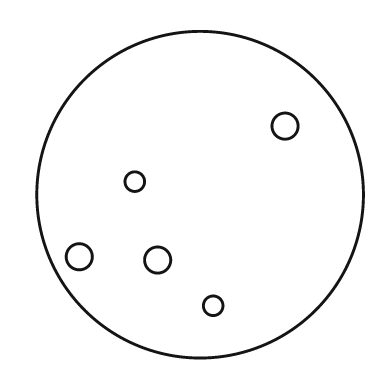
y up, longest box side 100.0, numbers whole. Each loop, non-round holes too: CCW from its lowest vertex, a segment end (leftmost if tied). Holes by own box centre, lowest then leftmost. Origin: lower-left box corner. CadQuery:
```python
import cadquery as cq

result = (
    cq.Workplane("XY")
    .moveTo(50.0, 50.0)
    .circle(50.0)
    .moveTo(54.0, 16.0)
    .circle(3.0)
    .moveTo(37.0, 30.0)
    .circle(4.0)
    .moveTo(13.0, 31.0)
    .circle(4.0)
    .moveTo(30.0, 54.0)
    .circle(3.0)
    .moveTo(76.0, 71.0)
    .circle(4.0)
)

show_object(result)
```